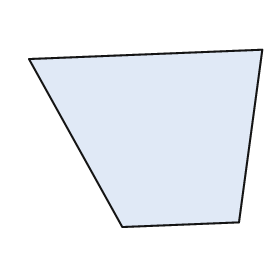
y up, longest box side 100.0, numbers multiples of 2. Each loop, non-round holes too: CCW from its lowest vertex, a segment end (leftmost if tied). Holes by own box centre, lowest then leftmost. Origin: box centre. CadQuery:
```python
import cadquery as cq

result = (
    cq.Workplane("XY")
    .moveTo(-10.0, -38.0)
    .lineTo(40.0, -36.0)
    .lineTo(50.0, 38.0)
    .lineTo(-50.0, 34.0)
    .close()
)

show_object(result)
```